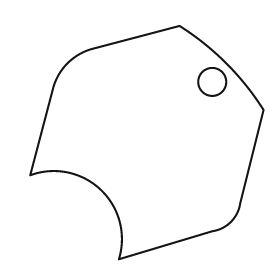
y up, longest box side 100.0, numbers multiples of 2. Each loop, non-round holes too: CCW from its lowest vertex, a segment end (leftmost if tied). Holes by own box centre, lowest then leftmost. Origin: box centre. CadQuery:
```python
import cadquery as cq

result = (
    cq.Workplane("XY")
    .moveTo(-12.0, -50.0)
    .lineTo(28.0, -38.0)
    .threePointArc((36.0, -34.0), (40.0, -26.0))
    .lineTo(50.0, 14.0)
    .threePointArc((34.0, 34.0), (14.0, 50.0))
    .lineTo(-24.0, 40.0)
    .threePointArc((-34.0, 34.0), (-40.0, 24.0))
    .lineTo(-50.0, -14.0)
    .threePointArc((-20.0, -20.0), (-12.0, -50.0))
    .close()
    .moveTo(28.0, 26.0)
    .circle(6.0)
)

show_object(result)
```